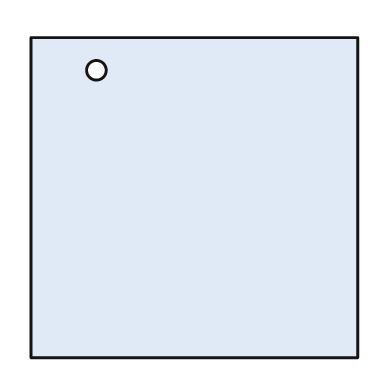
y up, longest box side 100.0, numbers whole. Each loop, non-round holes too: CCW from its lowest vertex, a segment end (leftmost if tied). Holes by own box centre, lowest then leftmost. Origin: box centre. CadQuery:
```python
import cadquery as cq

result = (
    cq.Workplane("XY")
    .moveTo(-50.0, -49.0)
    .lineTo(50.0, -49.0)
    .lineTo(50.0, 49.0)
    .lineTo(-50.0, 49.0)
    .close()
    .moveTo(-30.0, 39.0)
    .circle(3.0)
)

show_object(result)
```